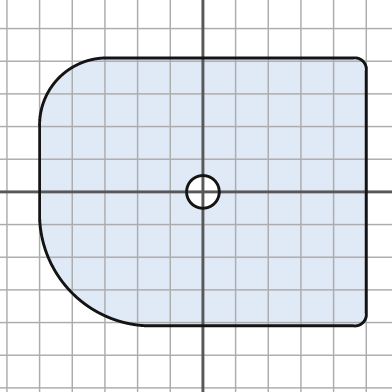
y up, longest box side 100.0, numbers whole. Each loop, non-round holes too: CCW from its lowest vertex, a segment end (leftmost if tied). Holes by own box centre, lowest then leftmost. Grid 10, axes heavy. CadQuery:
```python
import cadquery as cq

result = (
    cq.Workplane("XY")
    .moveTo(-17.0, -41.0)
    .lineTo(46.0, -41.0)
    .threePointArc((49.0, -40.0), (50.0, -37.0))
    .lineTo(50.0, 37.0)
    .threePointArc((49.0, 40.0), (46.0, 41.0))
    .lineTo(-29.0, 41.0)
    .threePointArc((-44.0, 35.0), (-50.0, 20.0))
    .lineTo(-50.0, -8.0)
    .threePointArc((-40.0, -31.0), (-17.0, -41.0))
    .close()
    .moveTo(0.0, 0.0)
    .circle(5.0)
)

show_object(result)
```